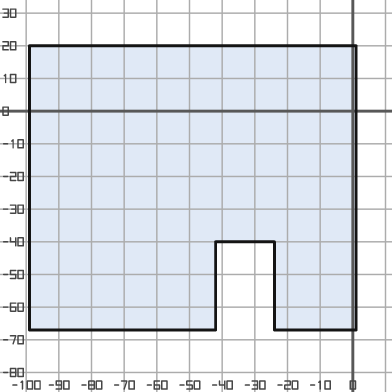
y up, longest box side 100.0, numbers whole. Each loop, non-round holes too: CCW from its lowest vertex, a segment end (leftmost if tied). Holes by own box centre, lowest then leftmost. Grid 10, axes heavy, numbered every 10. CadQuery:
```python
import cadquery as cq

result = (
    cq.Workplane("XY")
    .moveTo(-99.0, -67.0)
    .lineTo(-42.0, -67.0)
    .lineTo(-42.0, -40.0)
    .lineTo(-24.0, -40.0)
    .lineTo(-24.0, -67.0)
    .lineTo(1.0, -67.0)
    .lineTo(1.0, 20.0)
    .lineTo(-99.0, 20.0)
    .close()
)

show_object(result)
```